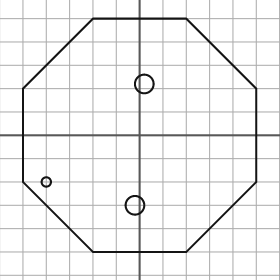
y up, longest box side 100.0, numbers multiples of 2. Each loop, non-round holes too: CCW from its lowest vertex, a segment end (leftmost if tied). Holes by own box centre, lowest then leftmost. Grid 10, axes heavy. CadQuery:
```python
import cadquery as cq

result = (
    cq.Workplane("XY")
    .moveTo(-20.0, -50.0)
    .lineTo(20.0, -50.0)
    .lineTo(50.0, -20.0)
    .lineTo(50.0, 20.0)
    .lineTo(20.0, 50.0)
    .lineTo(-20.0, 50.0)
    .lineTo(-50.0, 20.0)
    .lineTo(-50.0, -20.0)
    .close()
    .moveTo(-2.0, -30.0)
    .circle(4.0)
    .moveTo(-40.0, -20.0)
    .circle(2.0)
    .moveTo(2.0, 22.0)
    .circle(4.0)
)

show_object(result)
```